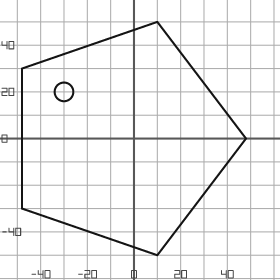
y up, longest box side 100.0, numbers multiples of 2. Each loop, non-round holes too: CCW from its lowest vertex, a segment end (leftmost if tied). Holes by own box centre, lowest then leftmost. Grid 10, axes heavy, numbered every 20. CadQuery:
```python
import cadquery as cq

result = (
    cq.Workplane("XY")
    .moveTo(10.0, -50.0)
    .lineTo(48.0, 0.0)
    .lineTo(10.0, 50.0)
    .lineTo(-48.0, 30.0)
    .lineTo(-48.0, -30.0)
    .close()
    .moveTo(-30.0, 20.0)
    .circle(4.0)
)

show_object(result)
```